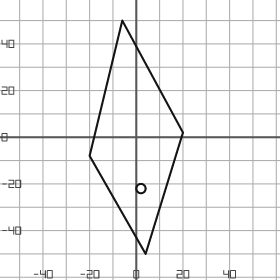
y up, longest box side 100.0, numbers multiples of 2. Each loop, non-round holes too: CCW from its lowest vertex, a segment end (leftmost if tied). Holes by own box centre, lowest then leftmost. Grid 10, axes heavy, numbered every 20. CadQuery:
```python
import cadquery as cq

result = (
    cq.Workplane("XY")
    .moveTo(4.0, -50.0)
    .lineTo(20.0, 2.0)
    .lineTo(-6.0, 50.0)
    .lineTo(-20.0, -8.0)
    .close()
    .moveTo(2.0, -22.0)
    .circle(2.0)
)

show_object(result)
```